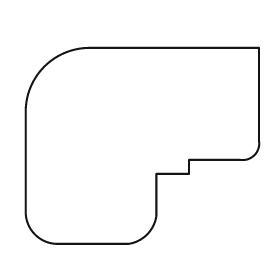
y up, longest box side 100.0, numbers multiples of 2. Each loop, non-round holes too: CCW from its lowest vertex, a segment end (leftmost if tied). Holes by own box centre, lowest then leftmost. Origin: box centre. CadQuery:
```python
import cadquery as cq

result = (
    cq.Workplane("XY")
    .moveTo(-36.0, -42.0)
    .lineTo(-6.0, -42.0)
    .threePointArc((2.0, -38.0), (6.0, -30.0))
    .lineTo(6.0, -12.0)
    .lineTo(20.0, -12.0)
    .lineTo(20.0, -6.0)
    .lineTo(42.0, -6.0)
    .threePointArc((48.0, -4.0), (50.0, 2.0))
    .lineTo(50.0, 42.0)
    .lineTo(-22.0, 42.0)
    .threePointArc((-42.0, 34.0), (-50.0, 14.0))
    .lineTo(-50.0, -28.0)
    .threePointArc((-46.0, -38.0), (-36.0, -42.0))
    .close()
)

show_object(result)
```